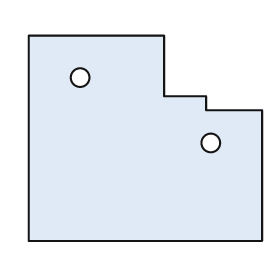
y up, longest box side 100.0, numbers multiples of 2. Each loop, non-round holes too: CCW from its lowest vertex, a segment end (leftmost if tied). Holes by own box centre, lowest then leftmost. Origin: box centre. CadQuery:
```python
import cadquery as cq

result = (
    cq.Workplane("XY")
    .moveTo(-50.0, -44.0)
    .lineTo(50.0, -44.0)
    .lineTo(50.0, 12.0)
    .lineTo(26.0, 12.0)
    .lineTo(26.0, 18.0)
    .lineTo(8.0, 18.0)
    .lineTo(8.0, 44.0)
    .lineTo(-50.0, 44.0)
    .close()
    .moveTo(28.0, -2.0)
    .circle(4.0)
    .moveTo(-28.0, 26.0)
    .circle(4.0)
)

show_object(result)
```